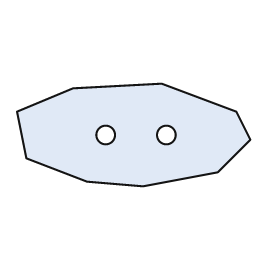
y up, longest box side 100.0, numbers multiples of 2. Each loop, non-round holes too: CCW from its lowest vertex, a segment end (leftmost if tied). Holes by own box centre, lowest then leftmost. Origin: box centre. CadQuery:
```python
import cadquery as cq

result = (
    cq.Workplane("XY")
    .moveTo(4.0, -22.0)
    .lineTo(36.0, -16.0)
    .lineTo(50.0, -2.0)
    .lineTo(44.0, 10.0)
    .lineTo(12.0, 22.0)
    .lineTo(-26.0, 20.0)
    .lineTo(-50.0, 10.0)
    .lineTo(-46.0, -10.0)
    .lineTo(-20.0, -20.0)
    .close()
    .moveTo(-12.0, 0.0)
    .circle(4.0)
    .moveTo(14.0, 0.0)
    .circle(4.0)
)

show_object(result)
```